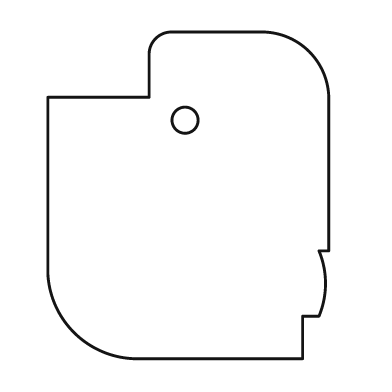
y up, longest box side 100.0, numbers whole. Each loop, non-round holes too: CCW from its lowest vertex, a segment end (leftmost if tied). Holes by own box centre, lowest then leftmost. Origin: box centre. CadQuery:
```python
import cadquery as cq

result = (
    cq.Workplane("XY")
    .moveTo(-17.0, -50.0)
    .lineTo(35.0, -50.0)
    .lineTo(35.0, -37.0)
    .lineTo(40.0, -37.0)
    .threePointArc((42.0, -27.0), (40.0, -17.0))
    .lineTo(43.0, -17.0)
    .lineTo(43.0, 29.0)
    .threePointArc((37.0, 44.0), (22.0, 50.0))
    .lineTo(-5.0, 50.0)
    .threePointArc((-10.0, 48.0), (-12.0, 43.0))
    .lineTo(-12.0, 30.0)
    .lineTo(-43.0, 30.0)
    .lineTo(-43.0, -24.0)
    .threePointArc((-35.0, -42.0), (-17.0, -50.0))
    .close()
    .moveTo(-1.0, 23.0)
    .circle(4.0)
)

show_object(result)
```